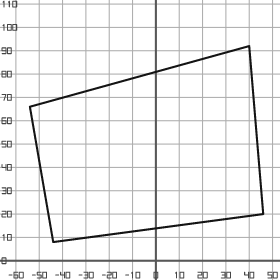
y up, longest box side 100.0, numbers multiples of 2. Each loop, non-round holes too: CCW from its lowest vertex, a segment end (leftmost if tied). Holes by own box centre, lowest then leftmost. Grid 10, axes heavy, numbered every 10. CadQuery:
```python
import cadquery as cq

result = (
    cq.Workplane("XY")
    .moveTo(-44.0, 8.0)
    .lineTo(46.0, 20.0)
    .lineTo(40.0, 92.0)
    .lineTo(-54.0, 66.0)
    .close()
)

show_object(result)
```